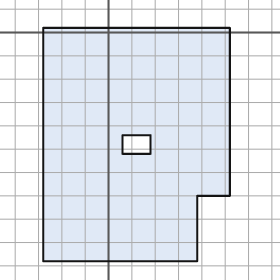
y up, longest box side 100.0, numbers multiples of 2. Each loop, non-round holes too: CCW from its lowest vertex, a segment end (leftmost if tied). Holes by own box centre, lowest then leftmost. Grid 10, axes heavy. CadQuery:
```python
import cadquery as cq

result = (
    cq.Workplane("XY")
    .moveTo(-28.0, -98.0)
    .lineTo(38.0, -98.0)
    .lineTo(38.0, -70.0)
    .lineTo(52.0, -70.0)
    .lineTo(52.0, 2.0)
    .lineTo(-28.0, 2.0)
    .close()
    .moveTo(6.0, -52.0)
    .lineTo(18.0, -52.0)
    .lineTo(18.0, -44.0)
    .lineTo(6.0, -44.0)
    .close()
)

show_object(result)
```